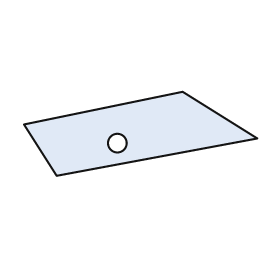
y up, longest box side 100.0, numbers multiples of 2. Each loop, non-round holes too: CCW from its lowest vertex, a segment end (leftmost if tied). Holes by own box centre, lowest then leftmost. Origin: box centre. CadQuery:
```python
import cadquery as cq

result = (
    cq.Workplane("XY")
    .moveTo(-36.0, -18.0)
    .lineTo(50.0, -2.0)
    .lineTo(18.0, 18.0)
    .lineTo(-50.0, 4.0)
    .close()
    .moveTo(-10.0, -4.0)
    .circle(4.0)
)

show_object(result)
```